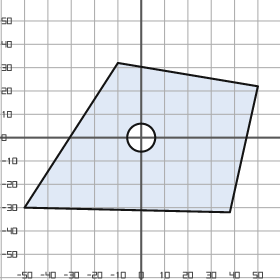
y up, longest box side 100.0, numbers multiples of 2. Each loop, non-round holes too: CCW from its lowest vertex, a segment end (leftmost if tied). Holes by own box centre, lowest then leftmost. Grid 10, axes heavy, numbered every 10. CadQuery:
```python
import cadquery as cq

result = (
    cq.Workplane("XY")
    .moveTo(38.0, -32.0)
    .lineTo(50.0, 22.0)
    .lineTo(-10.0, 32.0)
    .lineTo(-50.0, -30.0)
    .close()
    .moveTo(0.0, 0.0)
    .circle(6.0)
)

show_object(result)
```